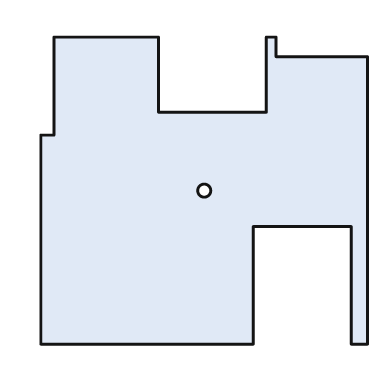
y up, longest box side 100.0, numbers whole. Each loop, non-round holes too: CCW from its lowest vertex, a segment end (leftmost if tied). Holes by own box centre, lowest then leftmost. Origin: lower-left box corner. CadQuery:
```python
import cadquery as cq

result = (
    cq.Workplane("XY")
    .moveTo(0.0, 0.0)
    .lineTo(65.0, 0.0)
    .lineTo(65.0, 36.0)
    .lineTo(95.0, 36.0)
    .lineTo(95.0, 0.0)
    .lineTo(100.0, 0.0)
    .lineTo(100.0, 88.0)
    .lineTo(72.0, 88.0)
    .lineTo(72.0, 94.0)
    .lineTo(69.0, 94.0)
    .lineTo(69.0, 71.0)
    .lineTo(36.0, 71.0)
    .lineTo(36.0, 94.0)
    .lineTo(4.0, 94.0)
    .lineTo(4.0, 64.0)
    .lineTo(0.0, 64.0)
    .close()
    .moveTo(50.0, 47.0)
    .circle(2.0)
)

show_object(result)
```